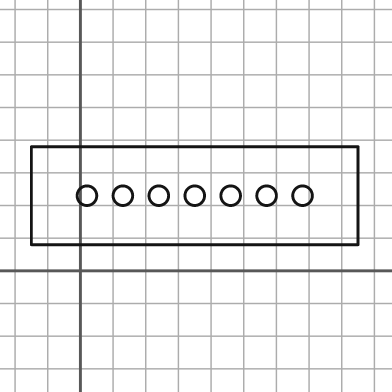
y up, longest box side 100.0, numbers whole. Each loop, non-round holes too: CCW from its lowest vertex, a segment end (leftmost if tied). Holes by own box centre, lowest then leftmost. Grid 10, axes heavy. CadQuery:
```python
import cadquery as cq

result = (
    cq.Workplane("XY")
    .moveTo(-15.0, 8.0)
    .lineTo(85.0, 8.0)
    .lineTo(85.0, 38.0)
    .lineTo(-15.0, 38.0)
    .close()
    .moveTo(2.0, 23.0)
    .circle(3.0)
    .moveTo(13.0, 23.0)
    .circle(3.0)
    .moveTo(24.0, 23.0)
    .circle(3.0)
    .moveTo(35.0, 23.0)
    .circle(3.0)
    .moveTo(46.0, 23.0)
    .circle(3.0)
    .moveTo(57.0, 23.0)
    .circle(3.0)
    .moveTo(68.0, 23.0)
    .circle(3.0)
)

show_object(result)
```